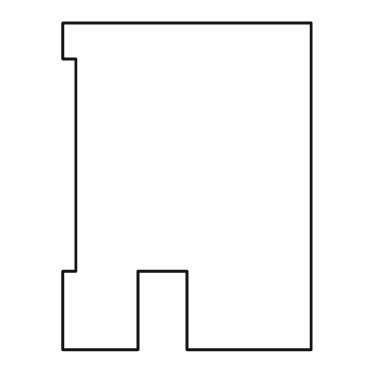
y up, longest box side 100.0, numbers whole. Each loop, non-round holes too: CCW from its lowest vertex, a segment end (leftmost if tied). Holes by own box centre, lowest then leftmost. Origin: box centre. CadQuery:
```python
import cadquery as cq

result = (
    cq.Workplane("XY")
    .moveTo(-38.0, -50.0)
    .lineTo(-15.0, -50.0)
    .lineTo(-15.0, -26.0)
    .lineTo(0.0, -26.0)
    .lineTo(0.0, -50.0)
    .lineTo(38.0, -50.0)
    .lineTo(38.0, 50.0)
    .lineTo(-38.0, 50.0)
    .lineTo(-38.0, 39.0)
    .lineTo(-34.0, 39.0)
    .lineTo(-34.0, -26.0)
    .lineTo(-38.0, -26.0)
    .close()
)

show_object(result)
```